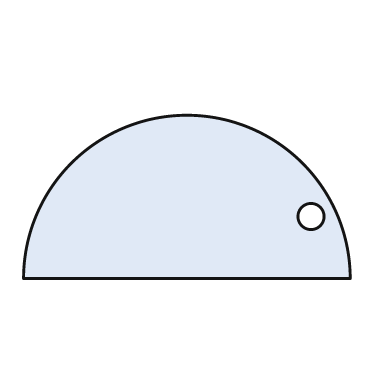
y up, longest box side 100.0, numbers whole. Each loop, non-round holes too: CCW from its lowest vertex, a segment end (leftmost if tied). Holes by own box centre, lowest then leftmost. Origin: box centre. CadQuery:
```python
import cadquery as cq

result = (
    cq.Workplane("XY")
    .moveTo(-50.0, -25.0)
    .lineTo(50.0, -25.0)
    .threePointArc((0.0, 25.0), (-50.0, -25.0))
    .close()
    .moveTo(38.0, -6.0)
    .circle(4.0)
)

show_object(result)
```